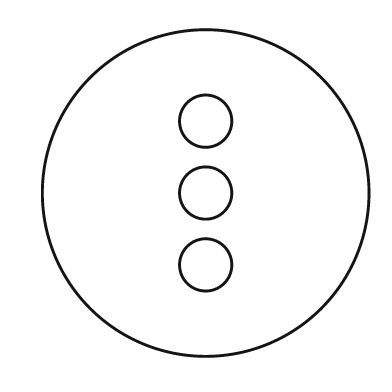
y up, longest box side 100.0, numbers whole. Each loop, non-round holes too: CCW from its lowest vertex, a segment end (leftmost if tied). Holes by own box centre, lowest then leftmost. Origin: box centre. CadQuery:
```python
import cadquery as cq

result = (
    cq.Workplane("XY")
    .moveTo(0.0, 0.0)
    .circle(50.0)
    .moveTo(0.0, -22.0)
    .circle(8.0)
    .moveTo(0.0, 0.0)
    .circle(8.0)
    .moveTo(0.0, 22.0)
    .circle(8.0)
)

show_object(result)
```